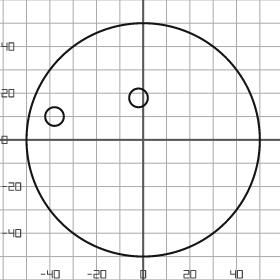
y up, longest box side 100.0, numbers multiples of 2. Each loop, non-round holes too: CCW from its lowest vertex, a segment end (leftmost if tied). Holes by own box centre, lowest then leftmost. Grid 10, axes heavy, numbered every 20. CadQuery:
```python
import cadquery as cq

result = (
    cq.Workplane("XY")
    .moveTo(0.0, 0.0)
    .circle(50.0)
    .moveTo(-38.0, 10.0)
    .circle(4.0)
    .moveTo(-2.0, 18.0)
    .circle(4.0)
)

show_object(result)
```